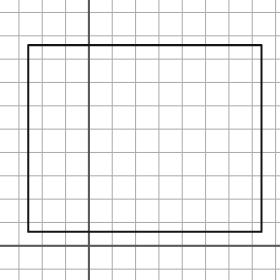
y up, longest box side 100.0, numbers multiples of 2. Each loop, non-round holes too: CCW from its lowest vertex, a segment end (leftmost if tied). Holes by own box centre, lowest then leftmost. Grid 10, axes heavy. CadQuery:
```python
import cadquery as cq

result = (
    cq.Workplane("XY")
    .moveTo(-26.0, 6.0)
    .lineTo(74.0, 6.0)
    .lineTo(74.0, 86.0)
    .lineTo(-26.0, 86.0)
    .close()
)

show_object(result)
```